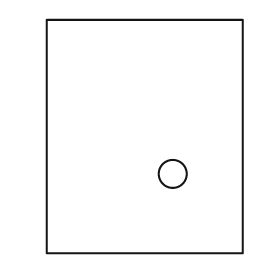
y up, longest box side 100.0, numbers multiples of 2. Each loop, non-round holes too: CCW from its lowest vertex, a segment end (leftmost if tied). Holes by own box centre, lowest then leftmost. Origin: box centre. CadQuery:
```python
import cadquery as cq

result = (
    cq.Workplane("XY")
    .moveTo(-42.0, -50.0)
    .lineTo(42.0, -50.0)
    .lineTo(42.0, 50.0)
    .lineTo(-42.0, 50.0)
    .close()
    .moveTo(12.0, -16.0)
    .circle(6.0)
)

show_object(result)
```